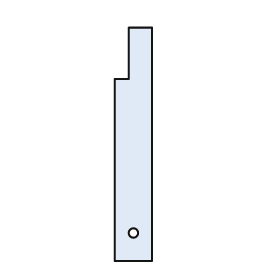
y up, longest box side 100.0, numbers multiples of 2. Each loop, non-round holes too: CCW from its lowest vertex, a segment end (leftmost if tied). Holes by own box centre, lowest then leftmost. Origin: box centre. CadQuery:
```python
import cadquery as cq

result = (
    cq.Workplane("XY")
    .moveTo(-8.0, -50.0)
    .lineTo(8.0, -50.0)
    .lineTo(8.0, 50.0)
    .lineTo(-2.0, 50.0)
    .lineTo(-2.0, 28.0)
    .lineTo(-8.0, 28.0)
    .close()
    .moveTo(0.0, -38.0)
    .circle(2.0)
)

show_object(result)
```